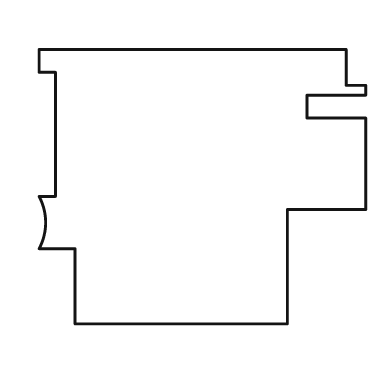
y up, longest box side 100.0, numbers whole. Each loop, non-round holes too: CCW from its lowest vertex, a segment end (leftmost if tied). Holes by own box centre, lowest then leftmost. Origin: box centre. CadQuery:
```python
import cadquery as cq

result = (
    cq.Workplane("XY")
    .moveTo(-39.0, -42.0)
    .lineTo(26.0, -42.0)
    .lineTo(26.0, -7.0)
    .lineTo(50.0, -7.0)
    .lineTo(50.0, 21.0)
    .lineTo(32.0, 21.0)
    .lineTo(32.0, 28.0)
    .lineTo(50.0, 28.0)
    .lineTo(50.0, 31.0)
    .lineTo(44.0, 31.0)
    .lineTo(44.0, 42.0)
    .lineTo(-50.0, 42.0)
    .lineTo(-50.0, 35.0)
    .lineTo(-45.0, 35.0)
    .lineTo(-45.0, -3.0)
    .lineTo(-50.0, -3.0)
    .threePointArc((-48.0, -11.0), (-50.0, -19.0))
    .lineTo(-39.0, -19.0)
    .close()
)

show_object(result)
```